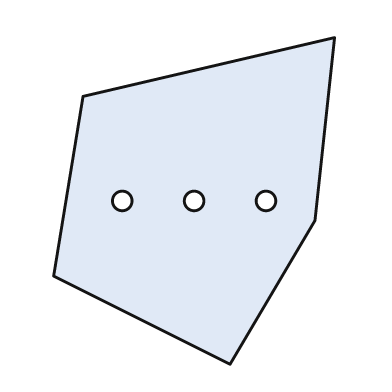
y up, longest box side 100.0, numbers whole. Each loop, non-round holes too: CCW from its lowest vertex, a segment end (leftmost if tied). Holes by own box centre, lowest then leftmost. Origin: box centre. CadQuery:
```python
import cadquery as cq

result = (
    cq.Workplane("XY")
    .moveTo(11.0, -50.0)
    .lineTo(37.0, -6.0)
    .lineTo(43.0, 50.0)
    .lineTo(-34.0, 32.0)
    .lineTo(-43.0, -23.0)
    .close()
    .moveTo(-22.0, 0.0)
    .circle(3.0)
    .moveTo(0.0, 0.0)
    .circle(3.0)
    .moveTo(22.0, 0.0)
    .circle(3.0)
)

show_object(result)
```